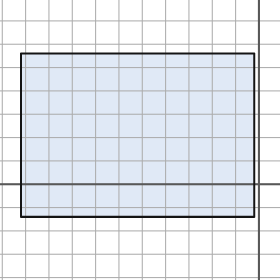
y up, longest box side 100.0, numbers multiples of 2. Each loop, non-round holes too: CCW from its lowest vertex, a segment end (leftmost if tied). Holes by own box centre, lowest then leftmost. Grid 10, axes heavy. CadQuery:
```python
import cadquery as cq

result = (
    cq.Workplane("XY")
    .moveTo(-102.0, -14.0)
    .lineTo(-2.0, -14.0)
    .lineTo(-2.0, 56.0)
    .lineTo(-102.0, 56.0)
    .close()
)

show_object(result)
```